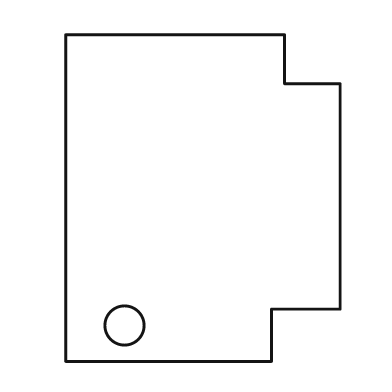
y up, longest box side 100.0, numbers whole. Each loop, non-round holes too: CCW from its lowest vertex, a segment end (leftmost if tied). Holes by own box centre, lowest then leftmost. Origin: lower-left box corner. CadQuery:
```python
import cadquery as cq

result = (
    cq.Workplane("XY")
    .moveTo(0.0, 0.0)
    .lineTo(63.0, 0.0)
    .lineTo(63.0, 16.0)
    .lineTo(84.0, 16.0)
    .lineTo(84.0, 85.0)
    .lineTo(67.0, 85.0)
    .lineTo(67.0, 100.0)
    .lineTo(0.0, 100.0)
    .close()
    .moveTo(18.0, 11.0)
    .circle(6.0)
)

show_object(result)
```